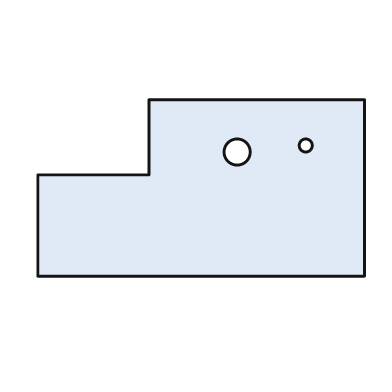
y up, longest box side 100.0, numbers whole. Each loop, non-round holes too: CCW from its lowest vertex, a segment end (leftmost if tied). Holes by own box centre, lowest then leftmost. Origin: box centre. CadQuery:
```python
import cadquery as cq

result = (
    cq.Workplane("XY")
    .moveTo(-50.0, -27.0)
    .lineTo(50.0, -27.0)
    .lineTo(50.0, 27.0)
    .lineTo(-16.0, 27.0)
    .lineTo(-16.0, 4.0)
    .lineTo(-50.0, 4.0)
    .close()
    .moveTo(11.0, 11.0)
    .circle(4.0)
    .moveTo(32.0, 13.0)
    .circle(2.0)
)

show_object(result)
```